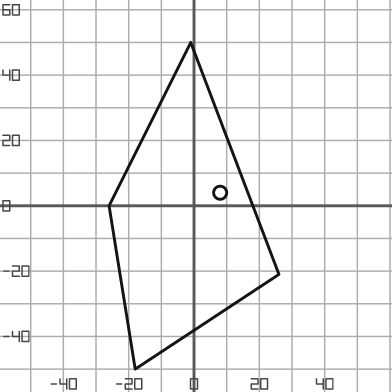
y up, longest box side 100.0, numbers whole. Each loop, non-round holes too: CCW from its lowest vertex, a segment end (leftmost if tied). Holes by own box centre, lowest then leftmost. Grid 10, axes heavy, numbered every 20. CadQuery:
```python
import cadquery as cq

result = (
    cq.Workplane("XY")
    .moveTo(-18.0, -50.0)
    .lineTo(26.0, -21.0)
    .lineTo(-1.0, 50.0)
    .lineTo(-26.0, 0.0)
    .close()
    .moveTo(8.0, 4.0)
    .circle(2.0)
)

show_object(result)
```